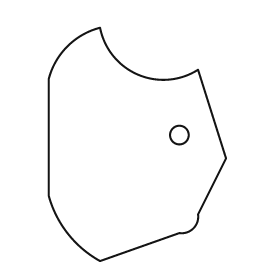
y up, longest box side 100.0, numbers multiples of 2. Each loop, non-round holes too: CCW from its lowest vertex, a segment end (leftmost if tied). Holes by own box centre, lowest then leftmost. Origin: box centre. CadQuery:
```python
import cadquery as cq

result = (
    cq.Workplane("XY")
    .moveTo(-16.0, -50.0)
    .lineTo(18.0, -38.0)
    .threePointArc((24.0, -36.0), (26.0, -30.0))
    .lineTo(38.0, -6.0)
    .lineTo(26.0, 32.0)
    .threePointArc((0.0, 30.0), (-16.0, 50.0))
    .threePointArc((-30.0, 42.0), (-38.0, 28.0))
    .lineTo(-38.0, -22.0)
    .threePointArc((-30.0, -38.0), (-16.0, -50.0))
    .close()
    .moveTo(18.0, 4.0)
    .circle(4.0)
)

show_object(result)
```